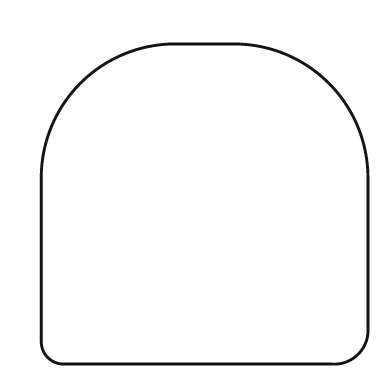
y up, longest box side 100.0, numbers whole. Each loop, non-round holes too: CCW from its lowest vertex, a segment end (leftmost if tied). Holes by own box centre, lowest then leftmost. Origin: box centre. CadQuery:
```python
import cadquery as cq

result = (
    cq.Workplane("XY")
    .moveTo(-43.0, -49.0)
    .lineTo(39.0, -49.0)
    .threePointArc((47.0, -46.0), (50.0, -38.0))
    .lineTo(50.0, 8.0)
    .threePointArc((38.0, 37.0), (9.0, 49.0))
    .lineTo(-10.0, 49.0)
    .threePointArc((-38.0, 37.0), (-50.0, 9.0))
    .lineTo(-50.0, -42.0)
    .threePointArc((-48.0, -47.0), (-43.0, -49.0))
    .close()
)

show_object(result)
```